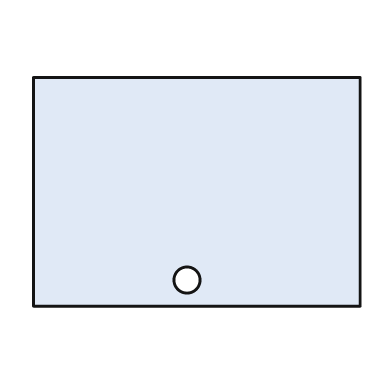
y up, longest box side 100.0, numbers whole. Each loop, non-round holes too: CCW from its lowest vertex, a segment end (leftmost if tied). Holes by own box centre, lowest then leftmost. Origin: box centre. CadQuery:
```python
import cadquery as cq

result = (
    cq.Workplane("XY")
    .moveTo(-50.0, -35.0)
    .lineTo(50.0, -35.0)
    .lineTo(50.0, 35.0)
    .lineTo(-50.0, 35.0)
    .close()
    .moveTo(-3.0, -27.0)
    .circle(4.0)
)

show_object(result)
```